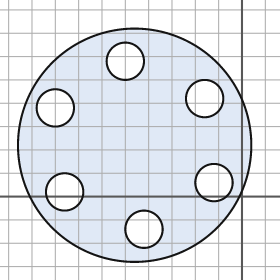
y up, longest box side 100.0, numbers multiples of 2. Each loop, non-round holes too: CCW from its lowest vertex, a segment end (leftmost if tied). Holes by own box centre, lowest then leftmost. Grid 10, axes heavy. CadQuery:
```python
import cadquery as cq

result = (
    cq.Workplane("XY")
    .moveTo(-46.0, 22.0)
    .circle(50.0)
    .moveTo(-42.0, -14.0)
    .circle(8.0)
    .moveTo(-76.0, 2.0)
    .circle(8.0)
    .moveTo(-12.0, 6.0)
    .circle(8.0)
    .moveTo(-80.0, 38.0)
    .circle(8.0)
    .moveTo(-16.0, 42.0)
    .circle(8.0)
    .moveTo(-50.0, 58.0)
    .circle(8.0)
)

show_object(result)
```